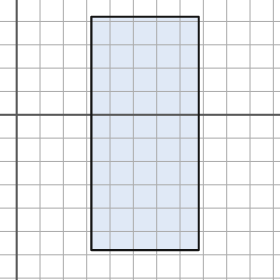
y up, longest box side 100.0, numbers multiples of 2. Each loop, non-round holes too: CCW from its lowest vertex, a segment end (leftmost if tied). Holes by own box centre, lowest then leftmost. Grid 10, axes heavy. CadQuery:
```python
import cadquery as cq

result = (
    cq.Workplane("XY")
    .moveTo(32.0, -58.0)
    .lineTo(78.0, -58.0)
    .lineTo(78.0, 42.0)
    .lineTo(32.0, 42.0)
    .close()
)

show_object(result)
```